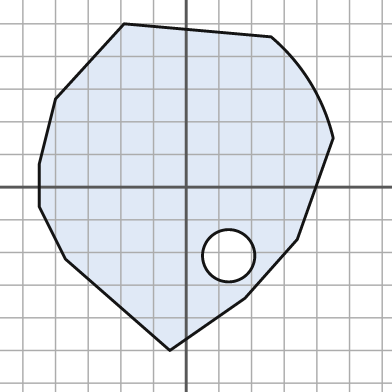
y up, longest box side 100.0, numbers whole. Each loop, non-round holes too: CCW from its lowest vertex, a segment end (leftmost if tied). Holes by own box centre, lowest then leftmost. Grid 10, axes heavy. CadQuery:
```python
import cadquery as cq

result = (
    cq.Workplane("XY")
    .moveTo(-5.0, -50.0)
    .lineTo(18.0, -34.0)
    .lineTo(34.0, -16.0)
    .lineTo(45.0, 15.0)
    .threePointArc((38.0, 32.0), (26.0, 46.0))
    .lineTo(-19.0, 50.0)
    .lineTo(-40.0, 27.0)
    .lineTo(-45.0, 7.0)
    .lineTo(-45.0, -6.0)
    .lineTo(-37.0, -22.0)
    .close()
    .moveTo(13.0, -21.0)
    .circle(8.0)
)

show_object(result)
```